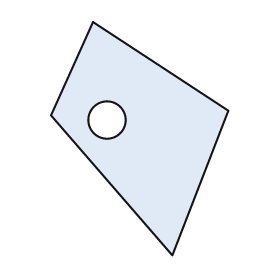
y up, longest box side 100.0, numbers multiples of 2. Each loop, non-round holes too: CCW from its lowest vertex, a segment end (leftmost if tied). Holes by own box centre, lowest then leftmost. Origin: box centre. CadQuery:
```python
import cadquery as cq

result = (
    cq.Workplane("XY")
    .moveTo(14.0, -50.0)
    .lineTo(38.0, 12.0)
    .lineTo(-20.0, 50.0)
    .lineTo(-38.0, 10.0)
    .close()
    .moveTo(-14.0, 8.0)
    .circle(8.0)
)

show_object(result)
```